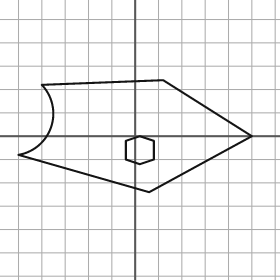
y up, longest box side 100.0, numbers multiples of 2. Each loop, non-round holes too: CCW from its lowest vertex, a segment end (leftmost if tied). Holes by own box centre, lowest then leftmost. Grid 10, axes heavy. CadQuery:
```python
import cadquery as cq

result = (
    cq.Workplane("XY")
    .moveTo(6.0, -24.0)
    .lineTo(50.0, 0.0)
    .lineTo(12.0, 24.0)
    .lineTo(-40.0, 22.0)
    .threePointArc((-36.0, 4.0), (-50.0, -8.0))
    .close()
    .moveTo(2.0, -12.0)
    .lineTo(8.0, -10.0)
    .lineTo(8.0, -2.0)
    .lineTo(2.0, 0.0)
    .lineTo(-4.0, -2.0)
    .lineTo(-4.0, -10.0)
    .close()
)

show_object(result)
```